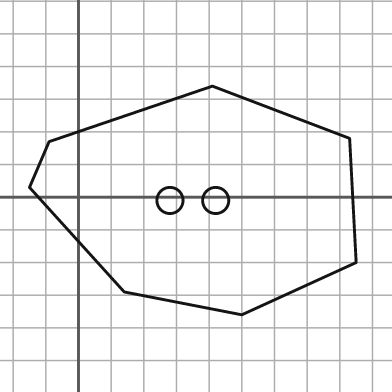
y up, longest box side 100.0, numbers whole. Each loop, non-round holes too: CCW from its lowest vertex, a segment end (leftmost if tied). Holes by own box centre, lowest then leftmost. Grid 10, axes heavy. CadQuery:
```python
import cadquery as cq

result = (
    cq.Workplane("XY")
    .moveTo(50.0, -36.0)
    .lineTo(85.0, -20.0)
    .lineTo(83.0, 18.0)
    .lineTo(41.0, 34.0)
    .lineTo(-9.0, 17.0)
    .lineTo(-15.0, 3.0)
    .lineTo(14.0, -29.0)
    .close()
    .moveTo(28.0, -1.0)
    .circle(4.0)
    .moveTo(42.0, -1.0)
    .circle(4.0)
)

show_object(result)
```